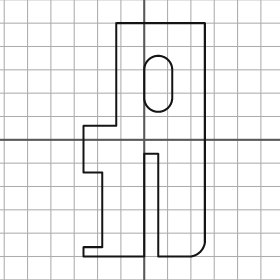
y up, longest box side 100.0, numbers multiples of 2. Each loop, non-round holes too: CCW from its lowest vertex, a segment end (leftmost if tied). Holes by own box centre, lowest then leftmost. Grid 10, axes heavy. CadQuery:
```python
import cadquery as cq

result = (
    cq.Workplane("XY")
    .moveTo(-26.0, -50.0)
    .lineTo(0.0, -50.0)
    .lineTo(0.0, -6.0)
    .lineTo(6.0, -6.0)
    .lineTo(6.0, -50.0)
    .lineTo(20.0, -50.0)
    .threePointArc((24.0, -48.0), (26.0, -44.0))
    .lineTo(26.0, 50.0)
    .lineTo(-12.0, 50.0)
    .lineTo(-12.0, 6.0)
    .lineTo(-26.0, 6.0)
    .lineTo(-26.0, -14.0)
    .lineTo(-18.0, -14.0)
    .lineTo(-18.0, -46.0)
    .lineTo(-26.0, -46.0)
    .close()
    .moveTo(0.0, 18.0)
    .threePointArc((6.0, 12.0), (12.0, 18.0))
    .lineTo(12.0, 30.0)
    .threePointArc((6.0, 36.0), (0.0, 30.0))
    .close()
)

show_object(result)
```